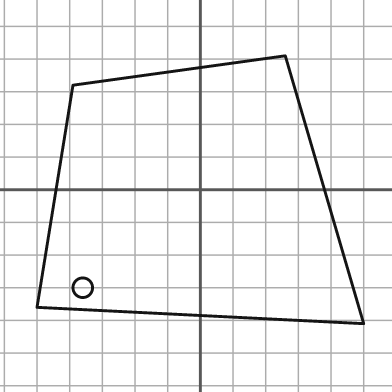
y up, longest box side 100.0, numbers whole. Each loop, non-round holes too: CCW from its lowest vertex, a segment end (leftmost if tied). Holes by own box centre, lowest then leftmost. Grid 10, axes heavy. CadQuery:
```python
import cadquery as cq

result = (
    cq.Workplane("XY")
    .moveTo(50.0, -41.0)
    .lineTo(26.0, 41.0)
    .lineTo(-39.0, 32.0)
    .lineTo(-50.0, -36.0)
    .close()
    .moveTo(-36.0, -30.0)
    .circle(3.0)
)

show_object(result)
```